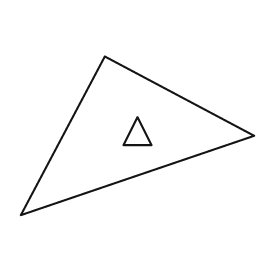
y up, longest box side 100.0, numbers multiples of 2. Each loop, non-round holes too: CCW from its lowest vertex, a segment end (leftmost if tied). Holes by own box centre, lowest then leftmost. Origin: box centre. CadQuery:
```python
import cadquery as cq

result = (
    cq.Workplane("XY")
    .moveTo(-50.0, -34.0)
    .lineTo(50.0, 0.0)
    .lineTo(-14.0, 34.0)
    .close()
    .moveTo(-6.0, -4.0)
    .lineTo(6.0, -4.0)
    .lineTo(0.0, 8.0)
    .close()
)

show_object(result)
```